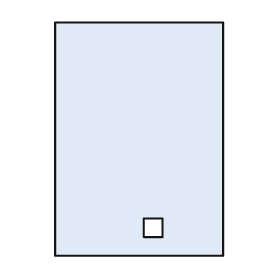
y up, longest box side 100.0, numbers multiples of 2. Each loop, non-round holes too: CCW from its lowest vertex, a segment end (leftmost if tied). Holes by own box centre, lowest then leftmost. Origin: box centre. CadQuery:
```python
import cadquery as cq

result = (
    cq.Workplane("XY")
    .moveTo(-36.0, -50.0)
    .lineTo(36.0, -50.0)
    .lineTo(36.0, 50.0)
    .lineTo(-36.0, 50.0)
    .close()
    .moveTo(2.0, -42.0)
    .lineTo(10.0, -42.0)
    .lineTo(10.0, -34.0)
    .lineTo(2.0, -34.0)
    .close()
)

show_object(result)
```